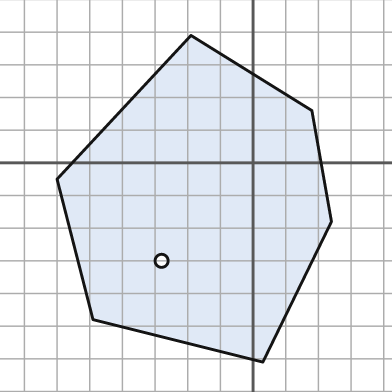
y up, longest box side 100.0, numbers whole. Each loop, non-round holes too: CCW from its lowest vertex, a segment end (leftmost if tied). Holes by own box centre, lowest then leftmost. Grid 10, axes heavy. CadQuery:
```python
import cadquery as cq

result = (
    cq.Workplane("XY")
    .moveTo(3.0, -61.0)
    .lineTo(24.0, -18.0)
    .lineTo(18.0, 16.0)
    .lineTo(-19.0, 39.0)
    .lineTo(-60.0, -5.0)
    .lineTo(-49.0, -48.0)
    .close()
    .moveTo(-28.0, -30.0)
    .circle(2.0)
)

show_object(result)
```